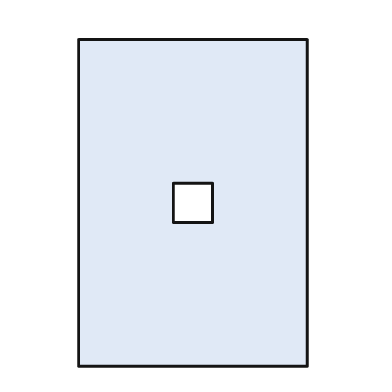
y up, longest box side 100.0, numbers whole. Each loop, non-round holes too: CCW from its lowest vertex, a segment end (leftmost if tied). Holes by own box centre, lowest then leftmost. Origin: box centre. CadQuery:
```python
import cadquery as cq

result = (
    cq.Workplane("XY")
    .moveTo(-35.0, -50.0)
    .lineTo(35.0, -50.0)
    .lineTo(35.0, 50.0)
    .lineTo(-35.0, 50.0)
    .close()
    .moveTo(-6.0, -6.0)
    .lineTo(6.0, -6.0)
    .lineTo(6.0, 6.0)
    .lineTo(-6.0, 6.0)
    .close()
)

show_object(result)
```